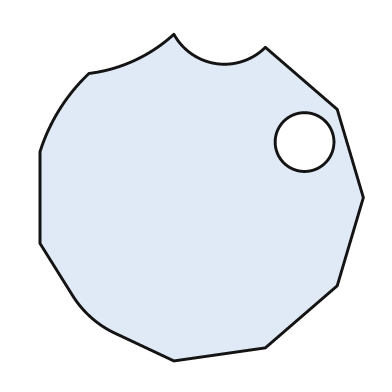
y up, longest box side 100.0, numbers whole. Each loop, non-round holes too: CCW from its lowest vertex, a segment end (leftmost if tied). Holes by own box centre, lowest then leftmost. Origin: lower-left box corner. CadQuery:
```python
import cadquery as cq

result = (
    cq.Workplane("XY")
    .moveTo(41.0, 0.0)
    .lineTo(69.0, 4.0)
    .lineTo(91.0, 23.0)
    .lineTo(99.0, 50.0)
    .lineTo(91.0, 77.0)
    .lineTo(69.0, 96.0)
    .threePointArc((54.0, 91.0), (41.0, 100.0))
    .threePointArc((29.0, 92.0), (15.0, 88.0))
    .threePointArc((6.0, 77.0), (0.0, 64.0))
    .lineTo(0.0, 36.0)
    .lineTo(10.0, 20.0)
    .threePointArc((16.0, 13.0), (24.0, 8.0))
    .close()
    .moveTo(81.0, 67.0)
    .circle(9.0)
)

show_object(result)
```